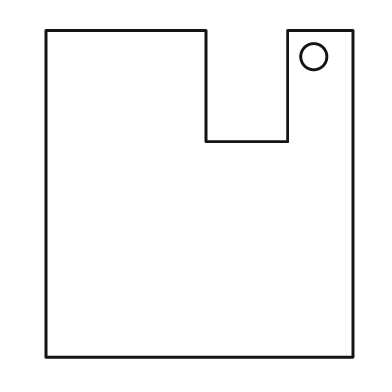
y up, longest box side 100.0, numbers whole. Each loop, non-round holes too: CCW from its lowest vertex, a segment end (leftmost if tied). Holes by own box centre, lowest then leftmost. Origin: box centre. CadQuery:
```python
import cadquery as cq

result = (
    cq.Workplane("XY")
    .moveTo(-47.0, -50.0)
    .lineTo(47.0, -50.0)
    .lineTo(47.0, 50.0)
    .lineTo(27.0, 50.0)
    .lineTo(27.0, 16.0)
    .lineTo(2.0, 16.0)
    .lineTo(2.0, 50.0)
    .lineTo(-47.0, 50.0)
    .close()
    .moveTo(35.0, 42.0)
    .circle(4.0)
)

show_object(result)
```